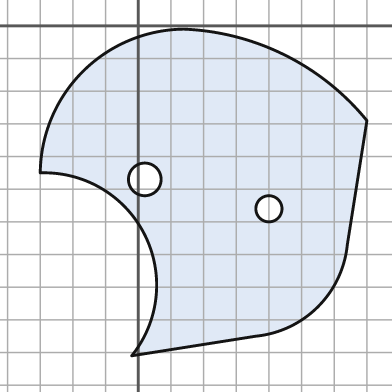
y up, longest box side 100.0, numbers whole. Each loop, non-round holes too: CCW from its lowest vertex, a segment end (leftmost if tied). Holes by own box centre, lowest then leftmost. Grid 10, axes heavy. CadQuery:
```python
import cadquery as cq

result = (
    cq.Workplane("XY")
    .moveTo(-2.0, -101.0)
    .lineTo(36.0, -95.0)
    .threePointArc((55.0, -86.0), (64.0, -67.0))
    .lineTo(70.0, -29.0)
    .threePointArc((45.0, -9.0), (14.0, -1.0))
    .threePointArc((-17.0, -14.0), (-30.0, -45.0))
    .threePointArc((2.0, -64.0), (-2.0, -101.0))
    .close()
    .moveTo(40.0, -56.0)
    .circle(4.0)
    .moveTo(2.0, -47.0)
    .circle(5.0)
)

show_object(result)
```